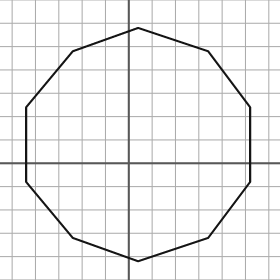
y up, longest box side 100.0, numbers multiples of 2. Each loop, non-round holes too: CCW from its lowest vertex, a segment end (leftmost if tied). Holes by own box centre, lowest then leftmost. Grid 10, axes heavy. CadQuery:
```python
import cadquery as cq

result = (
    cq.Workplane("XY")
    .moveTo(4.0, -42.0)
    .lineTo(34.0, -32.0)
    .lineTo(52.0, -8.0)
    .lineTo(52.0, 24.0)
    .lineTo(34.0, 48.0)
    .lineTo(4.0, 58.0)
    .lineTo(-24.0, 48.0)
    .lineTo(-44.0, 24.0)
    .lineTo(-44.0, -8.0)
    .lineTo(-24.0, -32.0)
    .close()
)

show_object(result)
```